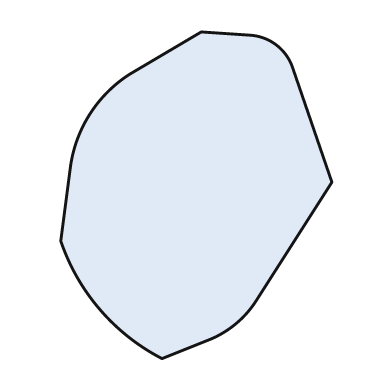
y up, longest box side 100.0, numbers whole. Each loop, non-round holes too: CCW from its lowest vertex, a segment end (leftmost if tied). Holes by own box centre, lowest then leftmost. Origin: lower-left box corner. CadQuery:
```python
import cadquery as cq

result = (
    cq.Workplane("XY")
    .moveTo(31.0, 0.0)
    .lineTo(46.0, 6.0)
    .threePointArc((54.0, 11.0), (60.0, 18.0))
    .lineTo(83.0, 54.0)
    .lineTo(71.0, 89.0)
    .threePointArc((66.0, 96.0), (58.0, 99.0))
    .lineTo(43.0, 100.0)
    .lineTo(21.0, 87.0)
    .threePointArc((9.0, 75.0), (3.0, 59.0))
    .lineTo(0.0, 36.0)
    .threePointArc((12.0, 15.0), (31.0, 0.0))
    .close()
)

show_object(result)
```